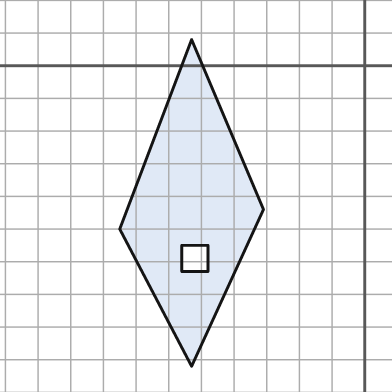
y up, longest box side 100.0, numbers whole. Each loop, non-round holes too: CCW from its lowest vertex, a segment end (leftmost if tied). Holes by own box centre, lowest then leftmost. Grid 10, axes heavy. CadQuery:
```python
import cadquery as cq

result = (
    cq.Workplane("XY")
    .moveTo(-53.0, -92.0)
    .lineTo(-31.0, -44.0)
    .lineTo(-53.0, 8.0)
    .lineTo(-75.0, -50.0)
    .close()
    .moveTo(-56.0, -63.0)
    .lineTo(-48.0, -63.0)
    .lineTo(-48.0, -55.0)
    .lineTo(-56.0, -55.0)
    .close()
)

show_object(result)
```